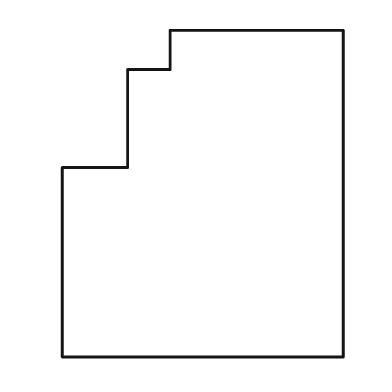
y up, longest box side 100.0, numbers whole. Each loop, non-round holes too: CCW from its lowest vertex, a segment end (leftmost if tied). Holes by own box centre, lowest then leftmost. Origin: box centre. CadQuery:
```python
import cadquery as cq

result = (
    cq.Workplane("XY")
    .moveTo(-43.0, -50.0)
    .lineTo(43.0, -50.0)
    .lineTo(43.0, 50.0)
    .lineTo(-10.0, 50.0)
    .lineTo(-10.0, 38.0)
    .lineTo(-23.0, 38.0)
    .lineTo(-23.0, 8.0)
    .lineTo(-43.0, 8.0)
    .close()
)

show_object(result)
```